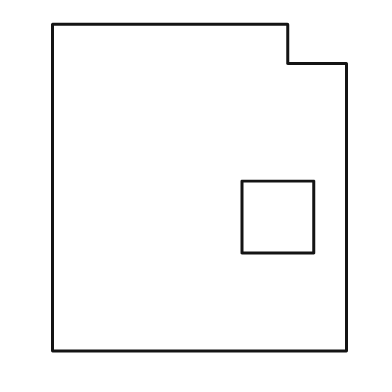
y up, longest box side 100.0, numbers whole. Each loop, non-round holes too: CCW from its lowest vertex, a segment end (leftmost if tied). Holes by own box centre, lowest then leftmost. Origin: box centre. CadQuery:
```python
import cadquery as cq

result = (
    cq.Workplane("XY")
    .moveTo(-45.0, -50.0)
    .lineTo(45.0, -50.0)
    .lineTo(45.0, 38.0)
    .lineTo(27.0, 38.0)
    .lineTo(27.0, 50.0)
    .lineTo(-45.0, 50.0)
    .close()
    .moveTo(13.0, -20.0)
    .lineTo(35.0, -20.0)
    .lineTo(35.0, 2.0)
    .lineTo(13.0, 2.0)
    .close()
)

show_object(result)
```